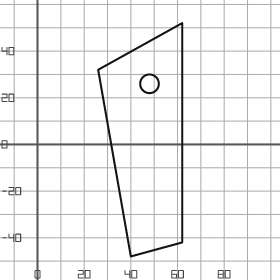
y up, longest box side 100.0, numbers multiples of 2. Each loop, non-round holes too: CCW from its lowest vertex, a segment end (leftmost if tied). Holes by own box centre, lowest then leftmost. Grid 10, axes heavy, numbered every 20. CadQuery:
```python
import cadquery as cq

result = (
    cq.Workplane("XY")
    .moveTo(40.0, -48.0)
    .lineTo(62.0, -42.0)
    .lineTo(62.0, 52.0)
    .lineTo(26.0, 32.0)
    .close()
    .moveTo(48.0, 26.0)
    .circle(4.0)
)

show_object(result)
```